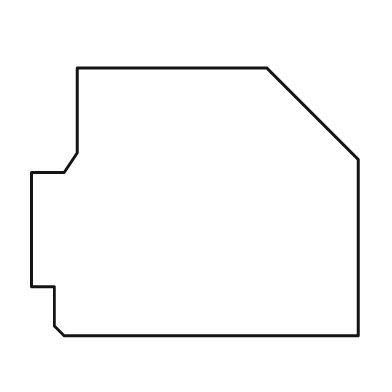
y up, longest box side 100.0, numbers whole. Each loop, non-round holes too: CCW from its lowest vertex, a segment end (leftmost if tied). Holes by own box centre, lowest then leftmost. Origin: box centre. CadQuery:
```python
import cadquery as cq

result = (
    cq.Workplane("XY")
    .moveTo(-40.0, -41.0)
    .lineTo(50.0, -41.0)
    .lineTo(50.0, 13.0)
    .lineTo(22.0, 41.0)
    .lineTo(-36.0, 41.0)
    .lineTo(-36.0, 15.0)
    .lineTo(-40.0, 9.0)
    .lineTo(-50.0, 9.0)
    .lineTo(-50.0, -26.0)
    .lineTo(-43.0, -26.0)
    .lineTo(-43.0, -38.0)
    .close()
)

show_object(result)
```